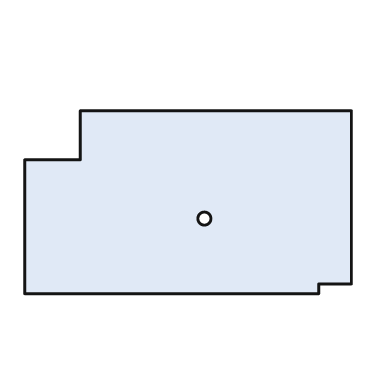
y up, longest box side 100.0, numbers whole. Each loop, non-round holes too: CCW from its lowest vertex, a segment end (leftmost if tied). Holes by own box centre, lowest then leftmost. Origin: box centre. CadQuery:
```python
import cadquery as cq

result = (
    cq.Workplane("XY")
    .moveTo(-50.0, -28.0)
    .lineTo(40.0, -28.0)
    .lineTo(40.0, -25.0)
    .lineTo(50.0, -25.0)
    .lineTo(50.0, 28.0)
    .lineTo(-33.0, 28.0)
    .lineTo(-33.0, 13.0)
    .lineTo(-50.0, 13.0)
    .close()
    .moveTo(5.0, -5.0)
    .circle(2.0)
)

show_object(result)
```